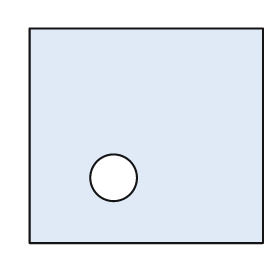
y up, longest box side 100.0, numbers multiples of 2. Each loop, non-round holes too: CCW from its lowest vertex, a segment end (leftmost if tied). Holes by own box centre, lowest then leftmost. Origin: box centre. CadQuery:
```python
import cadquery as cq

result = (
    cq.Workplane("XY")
    .moveTo(-50.0, -46.0)
    .lineTo(50.0, -46.0)
    .lineTo(50.0, 46.0)
    .lineTo(-50.0, 46.0)
    .close()
    .moveTo(-14.0, -18.0)
    .circle(10.0)
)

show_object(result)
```